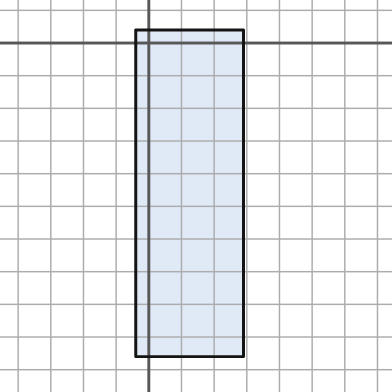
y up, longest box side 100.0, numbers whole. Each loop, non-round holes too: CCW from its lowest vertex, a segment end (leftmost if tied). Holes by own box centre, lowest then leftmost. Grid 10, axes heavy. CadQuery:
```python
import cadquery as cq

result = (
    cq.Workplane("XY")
    .moveTo(-4.0, -96.0)
    .lineTo(29.0, -96.0)
    .lineTo(29.0, 4.0)
    .lineTo(-4.0, 4.0)
    .close()
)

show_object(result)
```